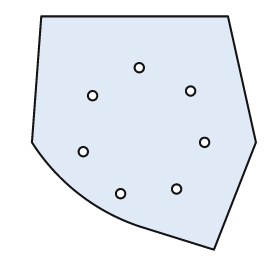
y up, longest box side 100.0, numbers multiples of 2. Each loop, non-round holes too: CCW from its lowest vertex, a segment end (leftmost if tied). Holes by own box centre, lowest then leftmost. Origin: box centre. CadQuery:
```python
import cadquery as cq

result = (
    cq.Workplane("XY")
    .moveTo(30.0, -50.0)
    .lineTo(48.0, -4.0)
    .lineTo(36.0, 50.0)
    .lineTo(-44.0, 50.0)
    .lineTo(-48.0, -4.0)
    .threePointArc((-28.0, -26.0), (-2.0, -40.0))
    .close()
    .moveTo(-10.0, -26.0)
    .circle(2.0)
    .moveTo(14.0, -24.0)
    .circle(2.0)
    .moveTo(-26.0, -8.0)
    .circle(2.0)
    .moveTo(26.0, -4.0)
    .circle(2.0)
    .moveTo(-22.0, 16.0)
    .circle(2.0)
    .moveTo(20.0, 18.0)
    .circle(2.0)
    .moveTo(-2.0, 28.0)
    .circle(2.0)
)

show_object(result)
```